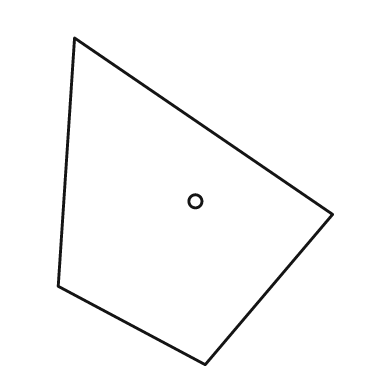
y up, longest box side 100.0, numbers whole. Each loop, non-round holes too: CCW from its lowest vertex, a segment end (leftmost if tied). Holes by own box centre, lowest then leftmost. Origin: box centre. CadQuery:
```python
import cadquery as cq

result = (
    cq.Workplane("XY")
    .moveTo(3.0, -50.0)
    .lineTo(42.0, -4.0)
    .lineTo(-37.0, 50.0)
    .lineTo(-42.0, -26.0)
    .close()
    .moveTo(0.0, 0.0)
    .circle(2.0)
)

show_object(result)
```